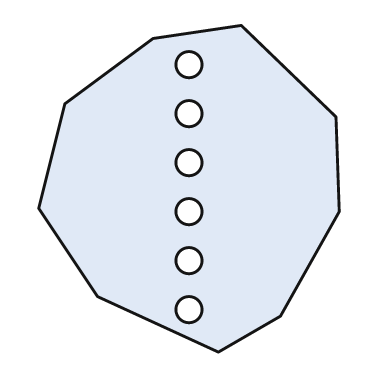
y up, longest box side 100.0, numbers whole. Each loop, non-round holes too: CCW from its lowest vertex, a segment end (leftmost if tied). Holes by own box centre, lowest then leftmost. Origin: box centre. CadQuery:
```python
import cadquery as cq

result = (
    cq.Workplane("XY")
    .moveTo(9.0, -50.0)
    .lineTo(28.0, -39.0)
    .lineTo(46.0, -7.0)
    .lineTo(45.0, 22.0)
    .lineTo(16.0, 50.0)
    .lineTo(-11.0, 46.0)
    .lineTo(-38.0, 26.0)
    .lineTo(-46.0, -6.0)
    .lineTo(-28.0, -33.0)
    .close()
    .moveTo(0.0, -37.0)
    .circle(4.0)
    .moveTo(0.0, -22.0)
    .circle(4.0)
    .moveTo(0.0, -7.0)
    .circle(4.0)
    .moveTo(0.0, 8.0)
    .circle(4.0)
    .moveTo(0.0, 23.0)
    .circle(4.0)
    .moveTo(0.0, 38.0)
    .circle(4.0)
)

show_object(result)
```